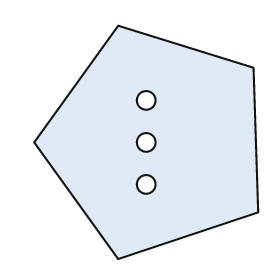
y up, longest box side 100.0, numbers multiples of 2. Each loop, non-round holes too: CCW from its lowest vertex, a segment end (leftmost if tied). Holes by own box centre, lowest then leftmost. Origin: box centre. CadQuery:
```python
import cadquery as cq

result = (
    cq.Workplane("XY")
    .moveTo(-12.0, -50.0)
    .lineTo(48.0, -30.0)
    .lineTo(46.0, 32.0)
    .lineTo(-12.0, 50.0)
    .lineTo(-48.0, 0.0)
    .close()
    .moveTo(0.0, -18.0)
    .circle(4.0)
    .moveTo(0.0, 0.0)
    .circle(4.0)
    .moveTo(0.0, 18.0)
    .circle(4.0)
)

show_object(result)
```